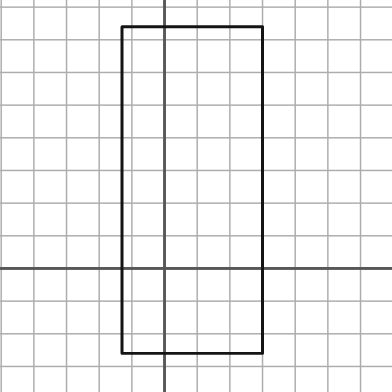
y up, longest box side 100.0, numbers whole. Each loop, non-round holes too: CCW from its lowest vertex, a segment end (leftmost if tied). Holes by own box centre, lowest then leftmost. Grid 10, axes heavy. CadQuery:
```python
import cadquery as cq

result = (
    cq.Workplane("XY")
    .moveTo(-13.0, -26.0)
    .lineTo(30.0, -26.0)
    .lineTo(30.0, 74.0)
    .lineTo(-13.0, 74.0)
    .close()
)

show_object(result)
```